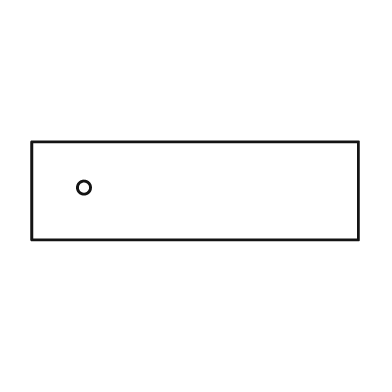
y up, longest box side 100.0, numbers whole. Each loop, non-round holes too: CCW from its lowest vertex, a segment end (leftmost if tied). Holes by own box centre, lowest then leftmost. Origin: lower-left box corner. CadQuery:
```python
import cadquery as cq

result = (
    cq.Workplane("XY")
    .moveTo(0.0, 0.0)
    .lineTo(100.0, 0.0)
    .lineTo(100.0, 30.0)
    .lineTo(0.0, 30.0)
    .close()
    .moveTo(16.0, 16.0)
    .circle(2.0)
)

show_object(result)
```